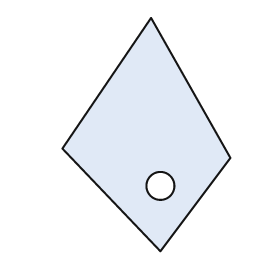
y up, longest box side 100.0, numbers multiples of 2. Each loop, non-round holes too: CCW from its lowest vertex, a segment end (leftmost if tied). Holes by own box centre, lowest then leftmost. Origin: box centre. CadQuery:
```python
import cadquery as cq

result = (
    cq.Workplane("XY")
    .moveTo(6.0, -50.0)
    .lineTo(36.0, -10.0)
    .lineTo(2.0, 50.0)
    .lineTo(-36.0, -6.0)
    .close()
    .moveTo(6.0, -22.0)
    .circle(6.0)
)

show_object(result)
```